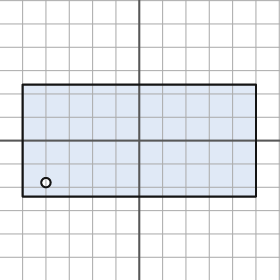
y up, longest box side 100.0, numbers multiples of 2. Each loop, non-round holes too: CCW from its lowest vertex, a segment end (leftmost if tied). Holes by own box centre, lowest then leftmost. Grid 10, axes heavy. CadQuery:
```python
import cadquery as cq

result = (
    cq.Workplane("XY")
    .moveTo(-50.0, -24.0)
    .lineTo(50.0, -24.0)
    .lineTo(50.0, 24.0)
    .lineTo(-50.0, 24.0)
    .close()
    .moveTo(-40.0, -18.0)
    .circle(2.0)
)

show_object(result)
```